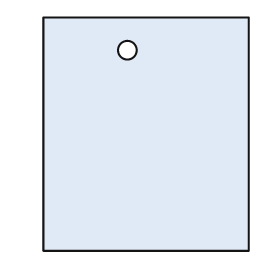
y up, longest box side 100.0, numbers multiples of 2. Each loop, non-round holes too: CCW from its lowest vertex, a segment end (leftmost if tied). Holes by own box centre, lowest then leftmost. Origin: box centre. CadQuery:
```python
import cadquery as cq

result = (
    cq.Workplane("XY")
    .moveTo(-44.0, -50.0)
    .lineTo(44.0, -50.0)
    .lineTo(44.0, 50.0)
    .lineTo(-44.0, 50.0)
    .close()
    .moveTo(-8.0, 36.0)
    .circle(4.0)
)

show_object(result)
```